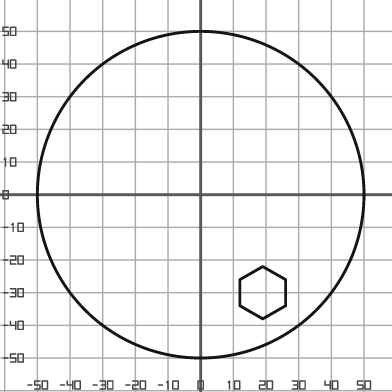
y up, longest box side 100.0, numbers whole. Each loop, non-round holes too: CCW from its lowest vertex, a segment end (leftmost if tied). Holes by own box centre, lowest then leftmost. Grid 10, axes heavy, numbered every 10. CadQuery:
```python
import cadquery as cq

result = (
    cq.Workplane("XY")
    .moveTo(0.0, 0.0)
    .circle(50.0)
    .moveTo(19.0, -38.0)
    .lineTo(26.0, -34.0)
    .lineTo(26.0, -26.0)
    .lineTo(19.0, -22.0)
    .lineTo(12.0, -26.0)
    .lineTo(12.0, -34.0)
    .close()
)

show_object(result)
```